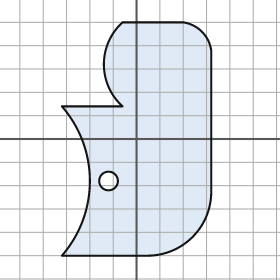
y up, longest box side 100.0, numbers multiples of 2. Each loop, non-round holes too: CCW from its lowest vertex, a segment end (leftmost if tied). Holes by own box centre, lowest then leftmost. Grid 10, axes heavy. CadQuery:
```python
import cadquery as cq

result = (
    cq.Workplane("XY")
    .moveTo(-32.0, -50.0)
    .lineTo(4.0, -50.0)
    .threePointArc((24.0, -42.0), (32.0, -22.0))
    .lineTo(32.0, 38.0)
    .threePointArc((28.0, 46.0), (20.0, 50.0))
    .lineTo(-6.0, 50.0)
    .threePointArc((-14.0, 32.0), (-6.0, 14.0))
    .lineTo(-32.0, 14.0)
    .threePointArc((-20.0, -18.0), (-32.0, -50.0))
    .close()
    .moveTo(-12.0, -18.0)
    .circle(4.0)
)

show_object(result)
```